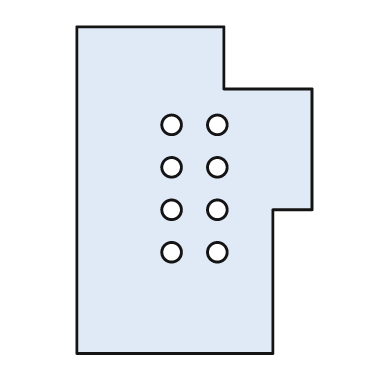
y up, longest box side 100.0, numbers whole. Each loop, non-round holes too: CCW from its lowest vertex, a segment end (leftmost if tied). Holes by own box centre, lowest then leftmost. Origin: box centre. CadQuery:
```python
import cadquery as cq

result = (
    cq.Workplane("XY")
    .moveTo(-36.0, -50.0)
    .lineTo(24.0, -50.0)
    .lineTo(24.0, -6.0)
    .lineTo(36.0, -6.0)
    .lineTo(36.0, 31.0)
    .lineTo(9.0, 31.0)
    .lineTo(9.0, 50.0)
    .lineTo(-36.0, 50.0)
    .close()
    .moveTo(-7.0, -19.0)
    .circle(3.0)
    .moveTo(7.0, -19.0)
    .circle(3.0)
    .moveTo(-7.0, -6.0)
    .circle(3.0)
    .moveTo(7.0, -6.0)
    .circle(3.0)
    .moveTo(-7.0, 7.0)
    .circle(3.0)
    .moveTo(7.0, 7.0)
    .circle(3.0)
    .moveTo(-7.0, 20.0)
    .circle(3.0)
    .moveTo(7.0, 20.0)
    .circle(3.0)
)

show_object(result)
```